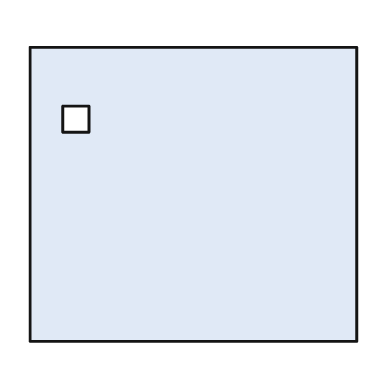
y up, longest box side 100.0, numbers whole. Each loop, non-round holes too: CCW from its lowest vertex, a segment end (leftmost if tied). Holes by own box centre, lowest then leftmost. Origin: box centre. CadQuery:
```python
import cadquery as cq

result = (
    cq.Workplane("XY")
    .moveTo(-50.0, -45.0)
    .lineTo(50.0, -45.0)
    .lineTo(50.0, 45.0)
    .lineTo(-50.0, 45.0)
    .close()
    .moveTo(-40.0, 19.0)
    .lineTo(-32.0, 19.0)
    .lineTo(-32.0, 27.0)
    .lineTo(-40.0, 27.0)
    .close()
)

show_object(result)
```